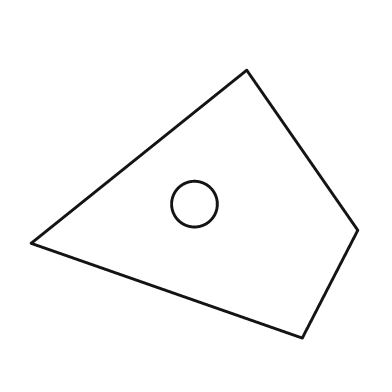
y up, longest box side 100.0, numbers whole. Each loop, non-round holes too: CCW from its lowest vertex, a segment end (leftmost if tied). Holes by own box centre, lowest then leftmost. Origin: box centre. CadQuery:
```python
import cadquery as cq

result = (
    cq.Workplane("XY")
    .moveTo(33.0, -41.0)
    .lineTo(50.0, -8.0)
    .lineTo(16.0, 41.0)
    .lineTo(-50.0, -12.0)
    .close()
    .moveTo(0.0, 0.0)
    .circle(7.0)
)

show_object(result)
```